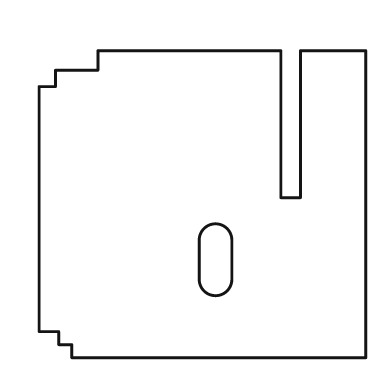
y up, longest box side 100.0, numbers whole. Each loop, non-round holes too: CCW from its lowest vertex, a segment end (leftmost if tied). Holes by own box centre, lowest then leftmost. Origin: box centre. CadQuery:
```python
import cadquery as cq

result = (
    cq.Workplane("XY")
    .moveTo(-40.0, -47.0)
    .lineTo(50.0, -47.0)
    .lineTo(50.0, 47.0)
    .lineTo(30.0, 47.0)
    .lineTo(30.0, 2.0)
    .lineTo(24.0, 2.0)
    .lineTo(24.0, 47.0)
    .lineTo(-32.0, 47.0)
    .lineTo(-32.0, 41.0)
    .lineTo(-45.0, 41.0)
    .lineTo(-45.0, 36.0)
    .lineTo(-50.0, 36.0)
    .lineTo(-50.0, -39.0)
    .lineTo(-44.0, -39.0)
    .lineTo(-44.0, -43.0)
    .lineTo(-40.0, -43.0)
    .close()
    .moveTo(-1.0, -23.0)
    .threePointArc((4.0, -28.0), (9.0, -23.0))
    .lineTo(9.0, -11.0)
    .threePointArc((4.0, -6.0), (-1.0, -11.0))
    .close()
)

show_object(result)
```